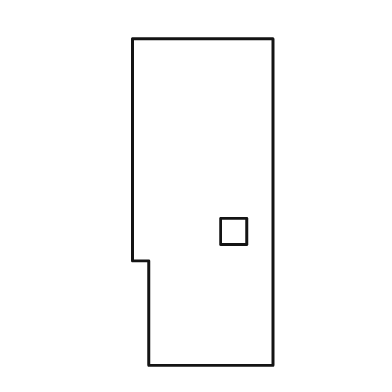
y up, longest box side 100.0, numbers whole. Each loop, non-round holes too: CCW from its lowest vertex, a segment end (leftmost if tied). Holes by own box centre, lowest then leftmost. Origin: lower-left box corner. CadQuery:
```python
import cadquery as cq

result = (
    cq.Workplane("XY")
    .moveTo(5.0, 0.0)
    .lineTo(43.0, 0.0)
    .lineTo(43.0, 100.0)
    .lineTo(0.0, 100.0)
    .lineTo(0.0, 32.0)
    .lineTo(5.0, 32.0)
    .close()
    .moveTo(27.0, 37.0)
    .lineTo(35.0, 37.0)
    .lineTo(35.0, 45.0)
    .lineTo(27.0, 45.0)
    .close()
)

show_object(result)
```